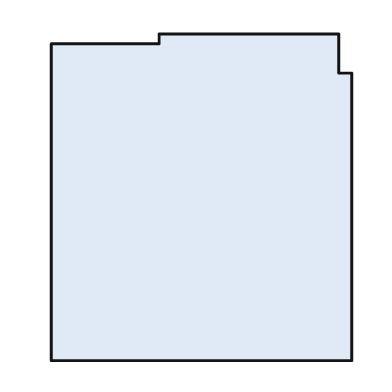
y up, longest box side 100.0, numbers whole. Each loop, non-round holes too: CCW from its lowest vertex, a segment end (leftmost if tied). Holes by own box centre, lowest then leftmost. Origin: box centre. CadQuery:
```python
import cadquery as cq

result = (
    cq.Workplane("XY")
    .moveTo(-46.0, -50.0)
    .lineTo(46.0, -50.0)
    .lineTo(46.0, 38.0)
    .lineTo(42.0, 38.0)
    .lineTo(42.0, 50.0)
    .lineTo(-13.0, 50.0)
    .lineTo(-13.0, 47.0)
    .lineTo(-46.0, 47.0)
    .close()
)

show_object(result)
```